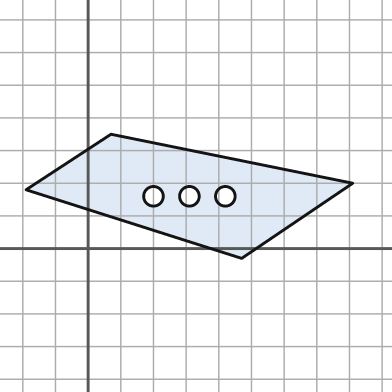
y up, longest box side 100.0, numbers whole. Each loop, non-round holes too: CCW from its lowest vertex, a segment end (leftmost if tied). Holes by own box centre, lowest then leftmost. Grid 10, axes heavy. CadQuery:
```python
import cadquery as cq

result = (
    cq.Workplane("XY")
    .moveTo(47.0, -3.0)
    .lineTo(81.0, 20.0)
    .lineTo(7.0, 35.0)
    .lineTo(-19.0, 18.0)
    .close()
    .moveTo(20.0, 16.0)
    .circle(3.0)
    .moveTo(31.0, 16.0)
    .circle(3.0)
    .moveTo(42.0, 16.0)
    .circle(3.0)
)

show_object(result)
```